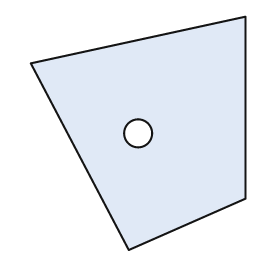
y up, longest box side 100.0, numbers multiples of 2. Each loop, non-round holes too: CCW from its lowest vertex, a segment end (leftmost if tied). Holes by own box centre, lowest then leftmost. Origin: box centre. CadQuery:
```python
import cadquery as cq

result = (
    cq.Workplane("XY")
    .moveTo(-4.0, -50.0)
    .lineTo(46.0, -28.0)
    .lineTo(46.0, 50.0)
    .lineTo(-46.0, 30.0)
    .close()
    .moveTo(0.0, 0.0)
    .circle(6.0)
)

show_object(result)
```